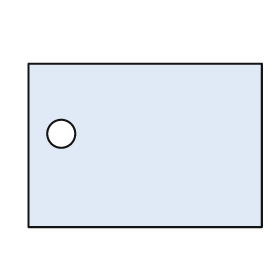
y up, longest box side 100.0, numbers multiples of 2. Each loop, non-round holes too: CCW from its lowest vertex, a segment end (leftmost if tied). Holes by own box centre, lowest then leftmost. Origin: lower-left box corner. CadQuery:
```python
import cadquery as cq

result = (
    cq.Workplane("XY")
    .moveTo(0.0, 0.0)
    .lineTo(100.0, 0.0)
    .lineTo(100.0, 70.0)
    .lineTo(0.0, 70.0)
    .close()
    .moveTo(14.0, 40.0)
    .circle(6.0)
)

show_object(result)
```